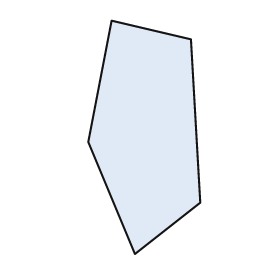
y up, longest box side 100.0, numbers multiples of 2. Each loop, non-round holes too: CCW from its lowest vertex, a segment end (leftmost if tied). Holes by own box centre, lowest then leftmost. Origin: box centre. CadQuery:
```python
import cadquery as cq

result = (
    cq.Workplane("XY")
    .moveTo(-4.0, -50.0)
    .lineTo(24.0, -28.0)
    .lineTo(20.0, 42.0)
    .lineTo(-14.0, 50.0)
    .lineTo(-24.0, -2.0)
    .close()
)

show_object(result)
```